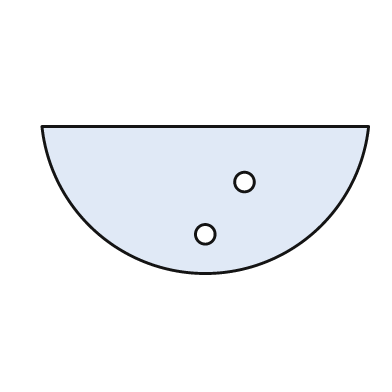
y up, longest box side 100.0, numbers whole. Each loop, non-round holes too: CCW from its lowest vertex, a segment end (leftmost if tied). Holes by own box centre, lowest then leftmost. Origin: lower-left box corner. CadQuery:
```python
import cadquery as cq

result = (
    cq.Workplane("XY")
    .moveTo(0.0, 45.0)
    .threePointArc((50.0, 0.0), (100.0, 45.0))
    .close()
    .moveTo(50.0, 12.0)
    .circle(3.0)
    .moveTo(62.0, 28.0)
    .circle(3.0)
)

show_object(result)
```